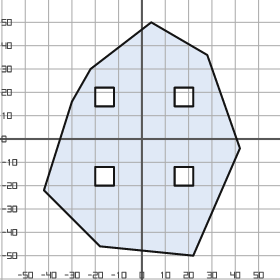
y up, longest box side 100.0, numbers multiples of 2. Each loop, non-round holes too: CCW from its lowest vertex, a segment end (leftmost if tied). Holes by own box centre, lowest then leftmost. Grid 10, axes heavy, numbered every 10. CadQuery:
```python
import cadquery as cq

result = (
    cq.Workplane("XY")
    .moveTo(22.0, -50.0)
    .lineTo(42.0, -4.0)
    .lineTo(28.0, 36.0)
    .lineTo(4.0, 50.0)
    .lineTo(-22.0, 30.0)
    .lineTo(-30.0, 16.0)
    .lineTo(-42.0, -22.0)
    .lineTo(-18.0, -46.0)
    .close()
    .moveTo(-20.0, -20.0)
    .lineTo(-12.0, -20.0)
    .lineTo(-12.0, -12.0)
    .lineTo(-20.0, -12.0)
    .close()
    .moveTo(14.0, -20.0)
    .lineTo(22.0, -20.0)
    .lineTo(22.0, -12.0)
    .lineTo(14.0, -12.0)
    .close()
    .moveTo(-20.0, 14.0)
    .lineTo(-12.0, 14.0)
    .lineTo(-12.0, 22.0)
    .lineTo(-20.0, 22.0)
    .close()
    .moveTo(14.0, 14.0)
    .lineTo(22.0, 14.0)
    .lineTo(22.0, 22.0)
    .lineTo(14.0, 22.0)
    .close()
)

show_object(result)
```